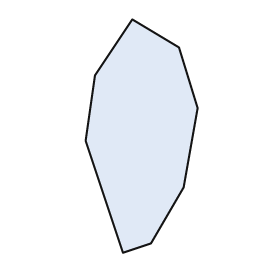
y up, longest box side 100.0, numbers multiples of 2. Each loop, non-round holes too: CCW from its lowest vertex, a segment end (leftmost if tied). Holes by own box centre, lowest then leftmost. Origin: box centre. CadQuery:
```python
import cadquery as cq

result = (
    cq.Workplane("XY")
    .moveTo(-8.0, -50.0)
    .lineTo(4.0, -46.0)
    .lineTo(18.0, -22.0)
    .lineTo(24.0, 12.0)
    .lineTo(16.0, 38.0)
    .lineTo(-4.0, 50.0)
    .lineTo(-20.0, 26.0)
    .lineTo(-24.0, -2.0)
    .close()
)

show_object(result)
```